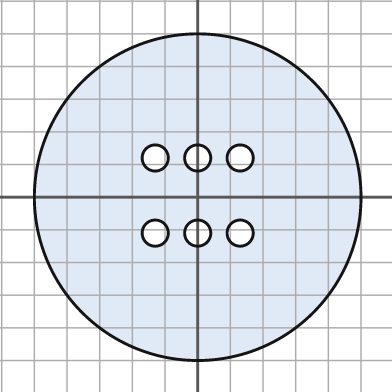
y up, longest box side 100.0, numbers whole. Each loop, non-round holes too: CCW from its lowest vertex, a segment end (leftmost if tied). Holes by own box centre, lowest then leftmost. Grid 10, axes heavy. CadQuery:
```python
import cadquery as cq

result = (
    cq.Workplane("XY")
    .moveTo(0.0, 0.0)
    .circle(50.0)
    .moveTo(-13.0, -11.0)
    .circle(4.0)
    .moveTo(0.0, -11.0)
    .circle(4.0)
    .moveTo(13.0, -11.0)
    .circle(4.0)
    .moveTo(-13.0, 12.0)
    .circle(4.0)
    .moveTo(0.0, 12.0)
    .circle(4.0)
    .moveTo(13.0, 12.0)
    .circle(4.0)
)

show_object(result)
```